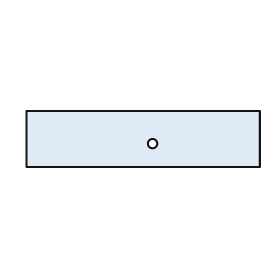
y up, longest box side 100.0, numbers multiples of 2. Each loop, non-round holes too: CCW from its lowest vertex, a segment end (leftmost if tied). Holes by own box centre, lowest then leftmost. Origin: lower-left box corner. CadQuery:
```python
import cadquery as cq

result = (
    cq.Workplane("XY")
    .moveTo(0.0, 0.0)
    .lineTo(100.0, 0.0)
    .lineTo(100.0, 24.0)
    .lineTo(0.0, 24.0)
    .close()
    .moveTo(54.0, 10.0)
    .circle(2.0)
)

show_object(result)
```